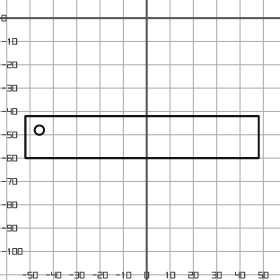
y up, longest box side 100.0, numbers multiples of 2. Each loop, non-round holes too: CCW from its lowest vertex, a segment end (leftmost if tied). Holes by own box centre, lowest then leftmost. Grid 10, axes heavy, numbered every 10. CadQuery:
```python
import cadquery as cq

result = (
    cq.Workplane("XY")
    .moveTo(-52.0, -60.0)
    .lineTo(48.0, -60.0)
    .lineTo(48.0, -42.0)
    .lineTo(-52.0, -42.0)
    .close()
    .moveTo(-46.0, -48.0)
    .circle(2.0)
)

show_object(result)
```